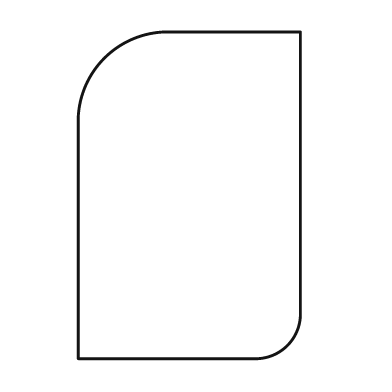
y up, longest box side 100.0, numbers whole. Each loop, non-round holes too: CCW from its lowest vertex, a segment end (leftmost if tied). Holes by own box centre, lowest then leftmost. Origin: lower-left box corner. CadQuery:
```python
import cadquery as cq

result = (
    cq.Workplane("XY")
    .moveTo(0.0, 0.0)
    .lineTo(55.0, 0.0)
    .threePointArc((64.0, 4.0), (68.0, 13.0))
    .lineTo(68.0, 100.0)
    .lineTo(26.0, 100.0)
    .threePointArc((8.0, 92.0), (0.0, 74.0))
    .close()
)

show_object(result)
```